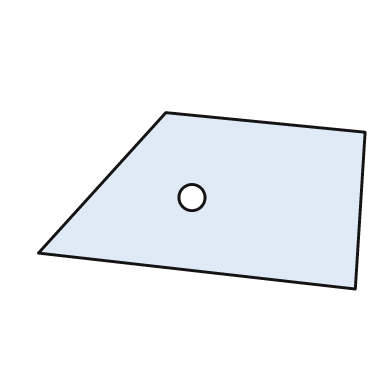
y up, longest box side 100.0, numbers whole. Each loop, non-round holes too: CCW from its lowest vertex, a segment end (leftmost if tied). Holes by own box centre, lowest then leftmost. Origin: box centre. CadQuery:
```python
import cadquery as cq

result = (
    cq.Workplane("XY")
    .moveTo(47.0, -27.0)
    .lineTo(50.0, 21.0)
    .lineTo(-11.0, 27.0)
    .lineTo(-50.0, -16.0)
    .close()
    .moveTo(-3.0, 1.0)
    .circle(4.0)
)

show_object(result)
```